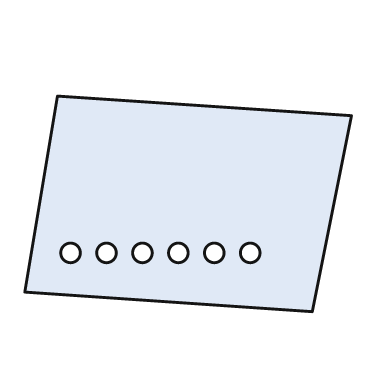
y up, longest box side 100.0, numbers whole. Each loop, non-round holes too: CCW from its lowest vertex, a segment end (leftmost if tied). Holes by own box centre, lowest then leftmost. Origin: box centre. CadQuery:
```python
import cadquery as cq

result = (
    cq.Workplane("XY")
    .moveTo(38.0, -33.0)
    .lineTo(50.0, 27.0)
    .lineTo(-40.0, 33.0)
    .lineTo(-50.0, -27.0)
    .close()
    .moveTo(-36.0, -15.0)
    .circle(3.0)
    .moveTo(-25.0, -15.0)
    .circle(3.0)
    .moveTo(-14.0, -15.0)
    .circle(3.0)
    .moveTo(-3.0, -15.0)
    .circle(3.0)
    .moveTo(8.0, -15.0)
    .circle(3.0)
    .moveTo(19.0, -15.0)
    .circle(3.0)
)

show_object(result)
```